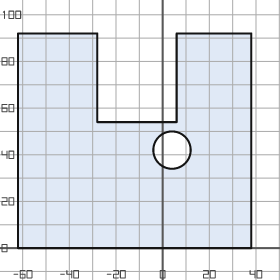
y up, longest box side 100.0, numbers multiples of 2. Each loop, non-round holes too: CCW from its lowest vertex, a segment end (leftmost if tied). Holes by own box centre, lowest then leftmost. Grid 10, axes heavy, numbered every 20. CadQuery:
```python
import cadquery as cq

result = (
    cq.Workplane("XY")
    .moveTo(-62.0, 0.0)
    .lineTo(38.0, 0.0)
    .lineTo(38.0, 92.0)
    .lineTo(6.0, 92.0)
    .lineTo(6.0, 54.0)
    .lineTo(-28.0, 54.0)
    .lineTo(-28.0, 92.0)
    .lineTo(-62.0, 92.0)
    .close()
    .moveTo(4.0, 42.0)
    .circle(8.0)
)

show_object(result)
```